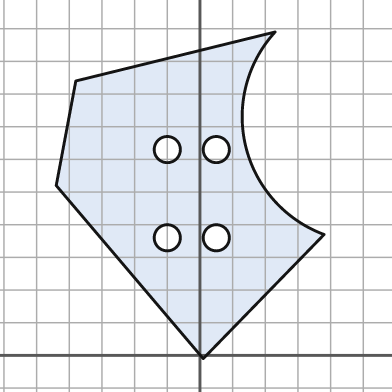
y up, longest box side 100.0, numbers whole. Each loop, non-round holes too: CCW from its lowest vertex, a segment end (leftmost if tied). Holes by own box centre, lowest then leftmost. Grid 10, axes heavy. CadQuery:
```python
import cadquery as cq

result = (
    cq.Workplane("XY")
    .moveTo(1.0, -1.0)
    .lineTo(38.0, 37.0)
    .threePointArc((14.0, 64.0), (23.0, 99.0))
    .lineTo(-38.0, 84.0)
    .lineTo(-44.0, 52.0)
    .close()
    .moveTo(-10.0, 36.0)
    .circle(4.0)
    .moveTo(5.0, 36.0)
    .circle(4.0)
    .moveTo(-10.0, 63.0)
    .circle(4.0)
    .moveTo(5.0, 63.0)
    .circle(4.0)
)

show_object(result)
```